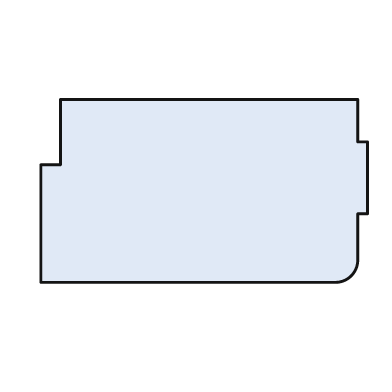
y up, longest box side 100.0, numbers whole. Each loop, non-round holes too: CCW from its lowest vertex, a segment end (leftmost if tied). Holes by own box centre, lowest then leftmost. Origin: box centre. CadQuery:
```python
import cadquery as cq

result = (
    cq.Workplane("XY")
    .moveTo(-50.0, -28.0)
    .lineTo(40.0, -28.0)
    .threePointArc((45.0, -26.0), (47.0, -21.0))
    .lineTo(47.0, -7.0)
    .lineTo(50.0, -7.0)
    .lineTo(50.0, 15.0)
    .lineTo(47.0, 15.0)
    .lineTo(47.0, 28.0)
    .lineTo(-44.0, 28.0)
    .lineTo(-44.0, 8.0)
    .lineTo(-50.0, 8.0)
    .close()
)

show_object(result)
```